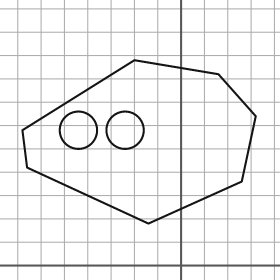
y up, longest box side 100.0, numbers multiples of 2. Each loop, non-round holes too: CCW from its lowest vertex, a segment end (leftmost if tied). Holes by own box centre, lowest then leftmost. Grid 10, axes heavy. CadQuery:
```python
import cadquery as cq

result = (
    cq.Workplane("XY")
    .moveTo(-14.0, 18.0)
    .lineTo(26.0, 36.0)
    .lineTo(32.0, 64.0)
    .lineTo(16.0, 82.0)
    .lineTo(-20.0, 88.0)
    .lineTo(-68.0, 58.0)
    .lineTo(-66.0, 42.0)
    .close()
    .moveTo(-44.0, 58.0)
    .circle(8.0)
    .moveTo(-24.0, 58.0)
    .circle(8.0)
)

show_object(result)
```